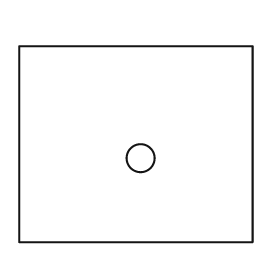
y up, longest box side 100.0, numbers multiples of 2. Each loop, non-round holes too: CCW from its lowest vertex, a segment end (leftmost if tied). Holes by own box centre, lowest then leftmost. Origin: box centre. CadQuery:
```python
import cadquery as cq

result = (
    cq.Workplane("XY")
    .moveTo(-50.0, -42.0)
    .lineTo(50.0, -42.0)
    .lineTo(50.0, 42.0)
    .lineTo(-50.0, 42.0)
    .close()
    .moveTo(2.0, -6.0)
    .circle(6.0)
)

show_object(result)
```